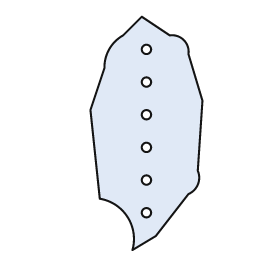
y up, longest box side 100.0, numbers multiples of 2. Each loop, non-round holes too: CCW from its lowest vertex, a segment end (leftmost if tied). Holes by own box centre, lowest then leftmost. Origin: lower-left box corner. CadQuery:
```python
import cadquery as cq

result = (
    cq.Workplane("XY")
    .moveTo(18.0, 0.0)
    .lineTo(28.0, 6.0)
    .lineTo(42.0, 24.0)
    .threePointArc((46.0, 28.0), (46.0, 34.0))
    .lineTo(48.0, 64.0)
    .lineTo(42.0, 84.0)
    .threePointArc((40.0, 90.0), (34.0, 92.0))
    .lineTo(22.0, 100.0)
    .lineTo(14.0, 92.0)
    .threePointArc((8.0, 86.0), (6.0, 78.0))
    .lineTo(0.0, 60.0)
    .lineTo(4.0, 22.0)
    .threePointArc((16.0, 14.0), (18.0, 0.0))
    .close()
    .moveTo(24.0, 16.0)
    .circle(2.0)
    .moveTo(24.0, 30.0)
    .circle(2.0)
    .moveTo(24.0, 44.0)
    .circle(2.0)
    .moveTo(24.0, 58.0)
    .circle(2.0)
    .moveTo(24.0, 72.0)
    .circle(2.0)
    .moveTo(24.0, 86.0)
    .circle(2.0)
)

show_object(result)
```